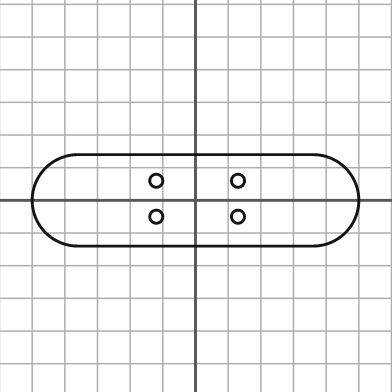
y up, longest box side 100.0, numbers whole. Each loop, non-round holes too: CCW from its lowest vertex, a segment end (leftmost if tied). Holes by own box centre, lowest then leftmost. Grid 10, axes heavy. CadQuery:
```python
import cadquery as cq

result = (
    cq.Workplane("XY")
    .moveTo(-36.0, -14.0)
    .lineTo(36.0, -14.0)
    .threePointArc((50.0, 0.0), (36.0, 14.0))
    .lineTo(-36.0, 14.0)
    .threePointArc((-50.0, 0.0), (-36.0, -14.0))
    .close()
    .moveTo(-12.0, -5.0)
    .circle(2.0)
    .moveTo(13.0, -5.0)
    .circle(2.0)
    .moveTo(-12.0, 6.0)
    .circle(2.0)
    .moveTo(13.0, 6.0)
    .circle(2.0)
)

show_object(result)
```